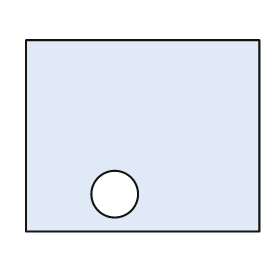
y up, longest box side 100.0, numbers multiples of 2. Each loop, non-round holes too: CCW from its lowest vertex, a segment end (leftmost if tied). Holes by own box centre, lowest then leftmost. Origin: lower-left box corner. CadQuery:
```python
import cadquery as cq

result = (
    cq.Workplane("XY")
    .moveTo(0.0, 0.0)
    .lineTo(100.0, 0.0)
    .lineTo(100.0, 82.0)
    .lineTo(0.0, 82.0)
    .close()
    .moveTo(38.0, 16.0)
    .circle(10.0)
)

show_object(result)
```